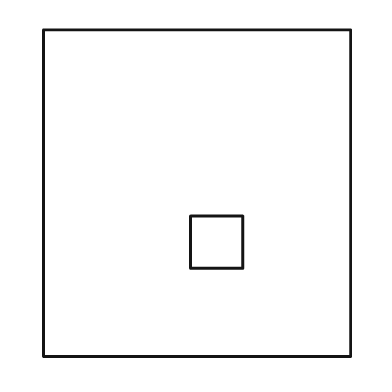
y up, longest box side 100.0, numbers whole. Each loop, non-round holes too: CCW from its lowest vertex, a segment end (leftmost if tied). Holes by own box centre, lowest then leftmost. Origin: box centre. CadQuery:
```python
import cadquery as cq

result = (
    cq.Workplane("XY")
    .moveTo(-47.0, -50.0)
    .lineTo(47.0, -50.0)
    .lineTo(47.0, 50.0)
    .lineTo(-47.0, 50.0)
    .close()
    .moveTo(-2.0, -23.0)
    .lineTo(14.0, -23.0)
    .lineTo(14.0, -7.0)
    .lineTo(-2.0, -7.0)
    .close()
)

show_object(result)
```